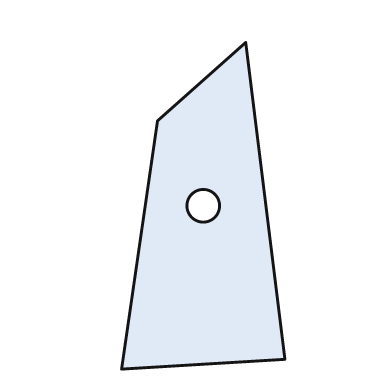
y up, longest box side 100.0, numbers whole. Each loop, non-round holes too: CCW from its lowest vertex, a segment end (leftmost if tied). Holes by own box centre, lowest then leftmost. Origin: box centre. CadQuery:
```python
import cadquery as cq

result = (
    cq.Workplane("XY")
    .moveTo(-25.0, -50.0)
    .lineTo(25.0, -47.0)
    .lineTo(13.0, 50.0)
    .lineTo(-14.0, 26.0)
    .close()
    .moveTo(0.0, 0.0)
    .circle(5.0)
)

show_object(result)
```